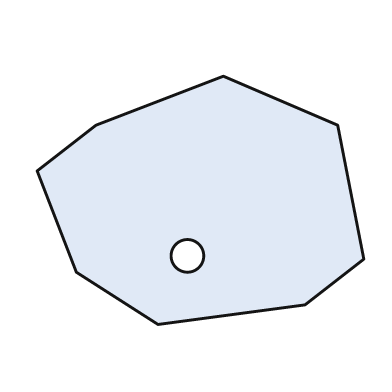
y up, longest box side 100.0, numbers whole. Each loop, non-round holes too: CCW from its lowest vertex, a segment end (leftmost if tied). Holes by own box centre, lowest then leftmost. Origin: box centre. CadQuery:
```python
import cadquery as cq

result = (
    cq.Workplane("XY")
    .moveTo(-13.0, -38.0)
    .lineTo(32.0, -32.0)
    .lineTo(50.0, -18.0)
    .lineTo(42.0, 23.0)
    .lineTo(7.0, 38.0)
    .lineTo(-32.0, 23.0)
    .lineTo(-50.0, 9.0)
    .lineTo(-38.0, -22.0)
    .close()
    .moveTo(-4.0, -17.0)
    .circle(5.0)
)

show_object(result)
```